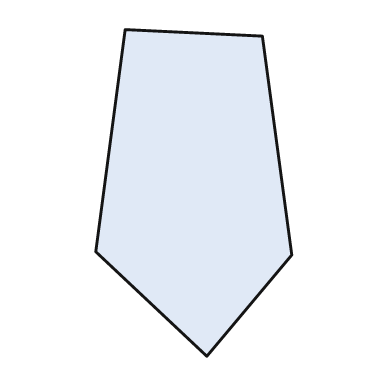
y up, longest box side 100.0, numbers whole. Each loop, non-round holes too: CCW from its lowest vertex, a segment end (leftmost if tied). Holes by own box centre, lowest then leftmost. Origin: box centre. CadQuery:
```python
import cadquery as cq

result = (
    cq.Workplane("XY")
    .moveTo(4.0, -50.0)
    .lineTo(30.0, -19.0)
    .lineTo(21.0, 48.0)
    .lineTo(-21.0, 50.0)
    .lineTo(-30.0, -18.0)
    .close()
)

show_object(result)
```